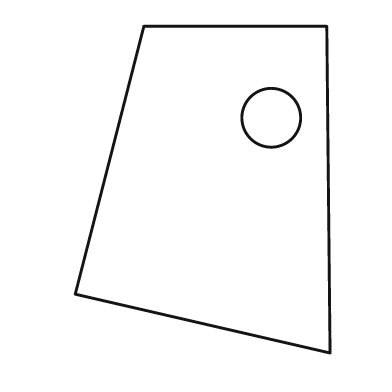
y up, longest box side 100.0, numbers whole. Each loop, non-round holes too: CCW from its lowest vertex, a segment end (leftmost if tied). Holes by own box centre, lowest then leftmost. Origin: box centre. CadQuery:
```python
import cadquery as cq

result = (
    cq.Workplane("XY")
    .moveTo(39.0, -50.0)
    .lineTo(38.0, 50.0)
    .lineTo(-18.0, 50.0)
    .lineTo(-39.0, -32.0)
    .close()
    .moveTo(21.0, 22.0)
    .circle(9.0)
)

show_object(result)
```